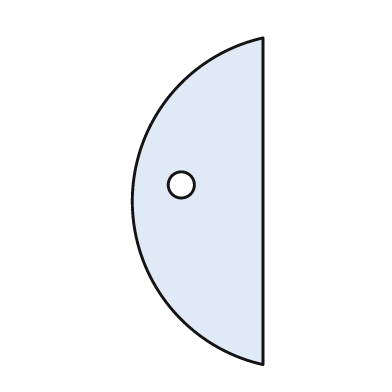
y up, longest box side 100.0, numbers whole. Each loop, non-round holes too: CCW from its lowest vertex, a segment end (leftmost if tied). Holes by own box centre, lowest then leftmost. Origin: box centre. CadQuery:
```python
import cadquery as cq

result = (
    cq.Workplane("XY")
    .moveTo(20.0, -50.0)
    .lineTo(20.0, 50.0)
    .threePointArc((-20.0, 0.0), (20.0, -50.0))
    .close()
    .moveTo(-5.0, 5.0)
    .circle(4.0)
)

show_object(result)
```